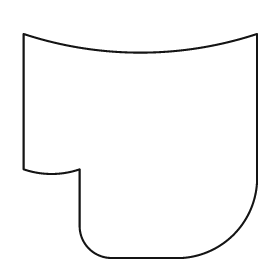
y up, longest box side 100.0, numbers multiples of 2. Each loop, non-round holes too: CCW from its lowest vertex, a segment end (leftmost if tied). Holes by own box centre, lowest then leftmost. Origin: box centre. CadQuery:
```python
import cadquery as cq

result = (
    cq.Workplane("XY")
    .moveTo(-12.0, -48.0)
    .lineTo(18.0, -48.0)
    .threePointArc((40.0, -38.0), (50.0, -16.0))
    .lineTo(50.0, 48.0)
    .threePointArc((0.0, 40.0), (-50.0, 48.0))
    .lineTo(-50.0, -10.0)
    .threePointArc((-38.0, -12.0), (-26.0, -10.0))
    .lineTo(-26.0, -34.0)
    .threePointArc((-22.0, -44.0), (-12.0, -48.0))
    .close()
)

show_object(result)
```